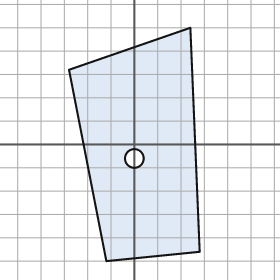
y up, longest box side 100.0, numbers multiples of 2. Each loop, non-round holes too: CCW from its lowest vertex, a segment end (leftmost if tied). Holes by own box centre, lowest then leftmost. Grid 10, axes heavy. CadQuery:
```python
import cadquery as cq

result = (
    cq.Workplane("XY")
    .moveTo(-12.0, -50.0)
    .lineTo(28.0, -46.0)
    .lineTo(24.0, 50.0)
    .lineTo(-28.0, 32.0)
    .close()
    .moveTo(0.0, -6.0)
    .circle(4.0)
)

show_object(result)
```